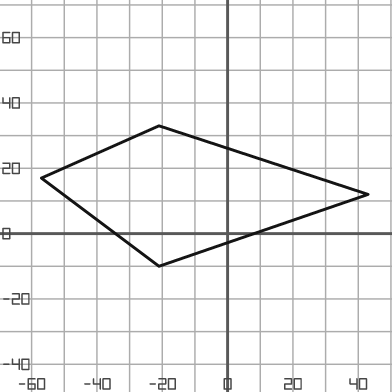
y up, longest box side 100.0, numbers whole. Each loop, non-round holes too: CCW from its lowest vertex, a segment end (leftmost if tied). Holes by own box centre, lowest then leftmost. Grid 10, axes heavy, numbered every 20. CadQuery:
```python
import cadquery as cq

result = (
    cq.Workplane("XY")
    .moveTo(-21.0, -10.0)
    .lineTo(43.0, 12.0)
    .lineTo(-21.0, 33.0)
    .lineTo(-57.0, 17.0)
    .close()
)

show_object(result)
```